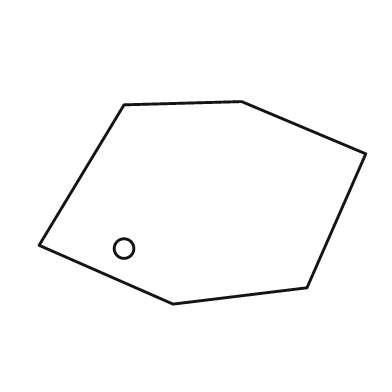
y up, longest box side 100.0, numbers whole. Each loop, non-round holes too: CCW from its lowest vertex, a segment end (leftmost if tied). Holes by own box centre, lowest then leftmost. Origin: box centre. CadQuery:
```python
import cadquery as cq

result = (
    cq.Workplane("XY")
    .moveTo(-9.0, -31.0)
    .lineTo(32.0, -26.0)
    .lineTo(50.0, 15.0)
    .lineTo(12.0, 31.0)
    .lineTo(-24.0, 30.0)
    .lineTo(-50.0, -13.0)
    .close()
    .moveTo(-24.0, -14.0)
    .circle(3.0)
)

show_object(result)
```